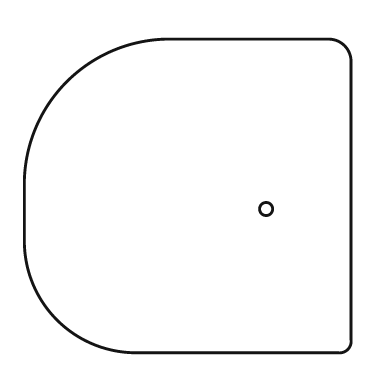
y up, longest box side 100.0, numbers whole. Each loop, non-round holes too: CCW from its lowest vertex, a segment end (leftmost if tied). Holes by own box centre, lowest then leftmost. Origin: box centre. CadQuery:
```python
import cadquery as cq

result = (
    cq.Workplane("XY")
    .moveTo(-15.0, -48.0)
    .lineTo(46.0, -48.0)
    .threePointArc((49.0, -47.0), (50.0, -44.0))
    .lineTo(50.0, 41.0)
    .threePointArc((48.0, 46.0), (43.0, 48.0))
    .lineTo(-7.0, 48.0)
    .threePointArc((-37.0, 35.0), (-50.0, 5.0))
    .lineTo(-50.0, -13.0)
    .threePointArc((-40.0, -38.0), (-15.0, -48.0))
    .close()
    .moveTo(24.0, -4.0)
    .circle(2.0)
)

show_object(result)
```